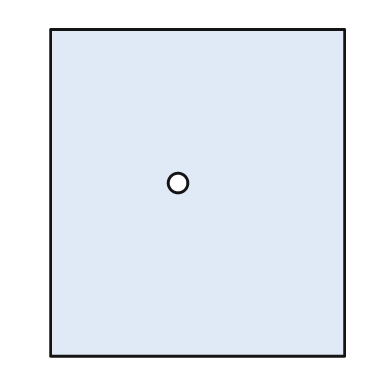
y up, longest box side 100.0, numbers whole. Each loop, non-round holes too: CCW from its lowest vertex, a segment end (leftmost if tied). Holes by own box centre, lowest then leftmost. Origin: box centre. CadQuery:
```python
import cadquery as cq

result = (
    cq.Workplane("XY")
    .moveTo(-45.0, -50.0)
    .lineTo(45.0, -50.0)
    .lineTo(45.0, 50.0)
    .lineTo(-45.0, 50.0)
    .close()
    .moveTo(-6.0, 3.0)
    .circle(3.0)
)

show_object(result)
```